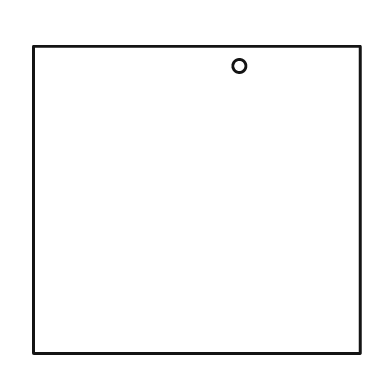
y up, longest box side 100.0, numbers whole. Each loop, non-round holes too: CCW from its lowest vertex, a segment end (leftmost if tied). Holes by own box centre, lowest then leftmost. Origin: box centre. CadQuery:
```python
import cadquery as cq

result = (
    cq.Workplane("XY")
    .moveTo(-50.0, -47.0)
    .lineTo(50.0, -47.0)
    .lineTo(50.0, 47.0)
    .lineTo(-50.0, 47.0)
    .close()
    .moveTo(13.0, 41.0)
    .circle(2.0)
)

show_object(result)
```